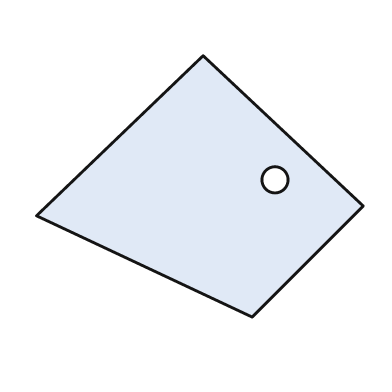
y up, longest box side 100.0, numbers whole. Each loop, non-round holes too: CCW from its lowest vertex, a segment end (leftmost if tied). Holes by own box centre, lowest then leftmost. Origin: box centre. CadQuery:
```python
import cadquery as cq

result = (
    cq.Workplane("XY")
    .moveTo(16.0, -40.0)
    .lineTo(50.0, -6.0)
    .lineTo(1.0, 40.0)
    .lineTo(-50.0, -9.0)
    .close()
    .moveTo(23.0, 2.0)
    .circle(4.0)
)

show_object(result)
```